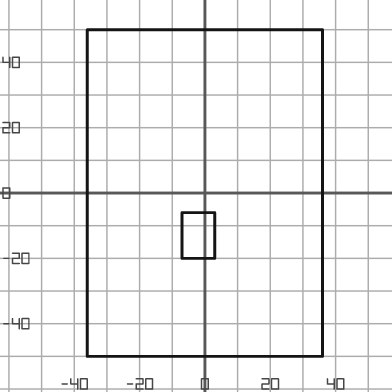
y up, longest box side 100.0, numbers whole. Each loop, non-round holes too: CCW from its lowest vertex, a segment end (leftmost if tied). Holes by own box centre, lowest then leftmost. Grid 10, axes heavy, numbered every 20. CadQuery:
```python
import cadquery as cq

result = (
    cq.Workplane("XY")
    .moveTo(-36.0, -50.0)
    .lineTo(36.0, -50.0)
    .lineTo(36.0, 50.0)
    .lineTo(-36.0, 50.0)
    .close()
    .moveTo(-7.0, -20.0)
    .lineTo(3.0, -20.0)
    .lineTo(3.0, -6.0)
    .lineTo(-7.0, -6.0)
    .close()
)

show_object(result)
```